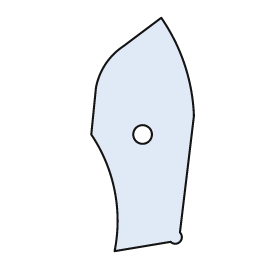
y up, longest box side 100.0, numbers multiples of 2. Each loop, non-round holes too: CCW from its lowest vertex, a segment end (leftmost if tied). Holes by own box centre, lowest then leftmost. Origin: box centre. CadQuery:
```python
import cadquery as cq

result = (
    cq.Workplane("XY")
    .moveTo(-12.0, -50.0)
    .lineTo(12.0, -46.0)
    .threePointArc((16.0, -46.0), (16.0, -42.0))
    .lineTo(22.0, 8.0)
    .threePointArc((18.0, 30.0), (8.0, 50.0))
    .lineTo(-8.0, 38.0)
    .threePointArc((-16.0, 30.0), (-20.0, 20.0))
    .lineTo(-22.0, 0.0)
    .threePointArc((-12.0, -24.0), (-12.0, -50.0))
    .close()
    .moveTo(0.0, 0.0)
    .circle(4.0)
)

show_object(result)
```